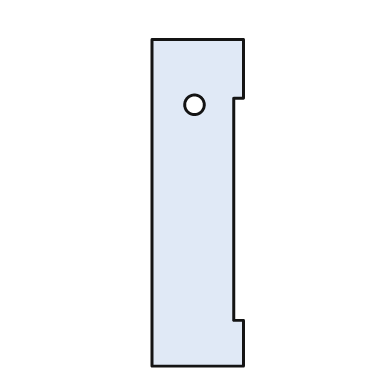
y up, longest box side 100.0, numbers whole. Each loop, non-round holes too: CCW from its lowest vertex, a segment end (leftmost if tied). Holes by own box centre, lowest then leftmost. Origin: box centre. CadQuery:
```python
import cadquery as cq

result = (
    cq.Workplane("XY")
    .moveTo(-14.0, -50.0)
    .lineTo(14.0, -50.0)
    .lineTo(14.0, -36.0)
    .lineTo(11.0, -36.0)
    .lineTo(11.0, 32.0)
    .lineTo(14.0, 32.0)
    .lineTo(14.0, 50.0)
    .lineTo(-14.0, 50.0)
    .close()
    .moveTo(-1.0, 30.0)
    .circle(3.0)
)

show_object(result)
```